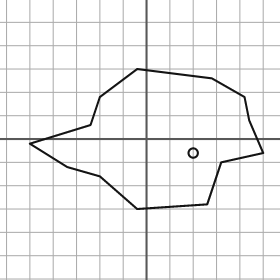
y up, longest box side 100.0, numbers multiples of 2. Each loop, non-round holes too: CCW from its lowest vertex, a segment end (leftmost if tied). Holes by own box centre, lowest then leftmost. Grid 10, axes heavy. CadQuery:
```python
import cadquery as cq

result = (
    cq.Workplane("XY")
    .moveTo(-4.0, -30.0)
    .lineTo(26.0, -28.0)
    .lineTo(32.0, -10.0)
    .lineTo(50.0, -6.0)
    .lineTo(44.0, 8.0)
    .lineTo(42.0, 18.0)
    .lineTo(28.0, 26.0)
    .lineTo(-4.0, 30.0)
    .lineTo(-20.0, 18.0)
    .lineTo(-24.0, 6.0)
    .lineTo(-50.0, -2.0)
    .lineTo(-34.0, -12.0)
    .lineTo(-20.0, -16.0)
    .close()
    .moveTo(20.0, -6.0)
    .circle(2.0)
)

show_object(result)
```